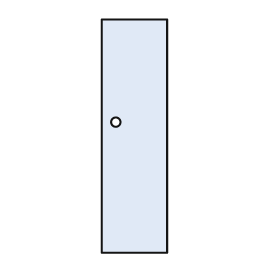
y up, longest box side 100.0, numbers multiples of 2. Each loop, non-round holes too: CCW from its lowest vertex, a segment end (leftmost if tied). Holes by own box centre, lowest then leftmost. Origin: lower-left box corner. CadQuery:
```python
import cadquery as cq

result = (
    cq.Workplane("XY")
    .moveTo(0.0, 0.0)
    .lineTo(28.0, 0.0)
    .lineTo(28.0, 100.0)
    .lineTo(0.0, 100.0)
    .close()
    .moveTo(6.0, 56.0)
    .circle(2.0)
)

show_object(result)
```